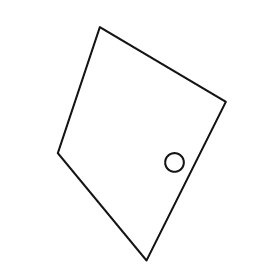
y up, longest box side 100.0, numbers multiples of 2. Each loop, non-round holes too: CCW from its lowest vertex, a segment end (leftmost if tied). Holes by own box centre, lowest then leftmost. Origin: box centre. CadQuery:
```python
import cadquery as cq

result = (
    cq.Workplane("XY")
    .moveTo(2.0, -50.0)
    .lineTo(36.0, 18.0)
    .lineTo(-18.0, 50.0)
    .lineTo(-36.0, -4.0)
    .close()
    .moveTo(14.0, -8.0)
    .circle(4.0)
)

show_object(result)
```